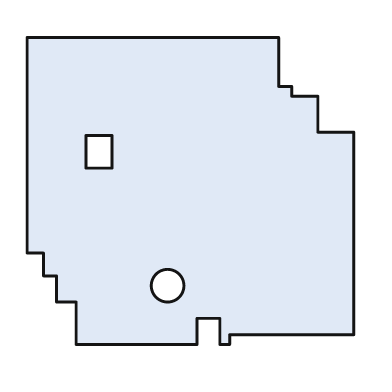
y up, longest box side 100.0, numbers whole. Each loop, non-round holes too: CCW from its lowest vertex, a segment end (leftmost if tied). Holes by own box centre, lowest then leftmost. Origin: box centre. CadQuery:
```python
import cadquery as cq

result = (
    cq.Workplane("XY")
    .moveTo(-35.0, -47.0)
    .lineTo(2.0, -47.0)
    .lineTo(2.0, -39.0)
    .lineTo(9.0, -39.0)
    .lineTo(9.0, -47.0)
    .lineTo(12.0, -47.0)
    .lineTo(12.0, -44.0)
    .lineTo(50.0, -44.0)
    .lineTo(50.0, 18.0)
    .lineTo(39.0, 18.0)
    .lineTo(39.0, 29.0)
    .lineTo(31.0, 29.0)
    .lineTo(31.0, 32.0)
    .lineTo(27.0, 32.0)
    .lineTo(27.0, 47.0)
    .lineTo(-50.0, 47.0)
    .lineTo(-50.0, -19.0)
    .lineTo(-45.0, -19.0)
    .lineTo(-45.0, -26.0)
    .lineTo(-41.0, -26.0)
    .lineTo(-41.0, -34.0)
    .lineTo(-35.0, -34.0)
    .close()
    .moveTo(-7.0, -29.0)
    .circle(5.0)
    .moveTo(-32.0, 7.0)
    .lineTo(-24.0, 7.0)
    .lineTo(-24.0, 17.0)
    .lineTo(-32.0, 17.0)
    .close()
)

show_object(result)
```